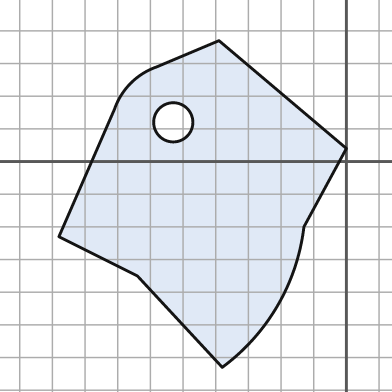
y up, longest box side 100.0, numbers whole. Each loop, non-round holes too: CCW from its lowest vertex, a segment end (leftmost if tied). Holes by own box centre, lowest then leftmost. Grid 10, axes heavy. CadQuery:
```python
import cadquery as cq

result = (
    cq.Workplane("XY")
    .moveTo(-38.0, -63.0)
    .threePointArc((-21.0, -44.0), (-13.0, -20.0))
    .lineTo(0.0, 4.0)
    .lineTo(-39.0, 37.0)
    .lineTo(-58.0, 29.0)
    .threePointArc((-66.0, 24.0), (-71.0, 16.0))
    .lineTo(-88.0, -23.0)
    .lineTo(-64.0, -35.0)
    .close()
    .moveTo(-53.0, 12.0)
    .circle(6.0)
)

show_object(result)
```